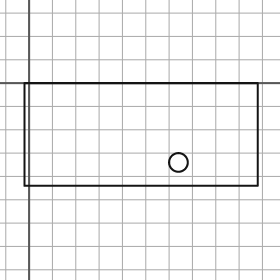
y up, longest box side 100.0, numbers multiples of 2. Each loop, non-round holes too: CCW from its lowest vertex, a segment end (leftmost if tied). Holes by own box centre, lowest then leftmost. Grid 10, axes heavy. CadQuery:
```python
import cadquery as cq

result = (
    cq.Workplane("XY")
    .moveTo(-2.0, -44.0)
    .lineTo(98.0, -44.0)
    .lineTo(98.0, 0.0)
    .lineTo(-2.0, 0.0)
    .close()
    .moveTo(64.0, -34.0)
    .circle(4.0)
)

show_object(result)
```